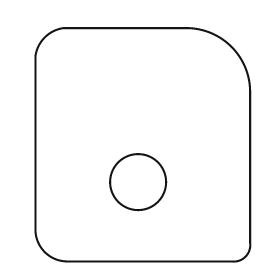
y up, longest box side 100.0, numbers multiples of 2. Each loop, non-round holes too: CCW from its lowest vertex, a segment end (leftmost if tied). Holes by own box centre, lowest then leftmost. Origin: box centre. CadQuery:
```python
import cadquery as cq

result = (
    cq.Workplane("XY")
    .moveTo(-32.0, -50.0)
    .lineTo(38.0, -50.0)
    .threePointArc((44.0, -48.0), (46.0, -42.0))
    .lineTo(46.0, 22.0)
    .threePointArc((38.0, 42.0), (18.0, 50.0))
    .lineTo(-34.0, 50.0)
    .threePointArc((-42.0, 46.0), (-46.0, 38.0))
    .lineTo(-46.0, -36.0)
    .threePointArc((-42.0, -46.0), (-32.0, -50.0))
    .close()
    .moveTo(-2.0, -16.0)
    .circle(12.0)
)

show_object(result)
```